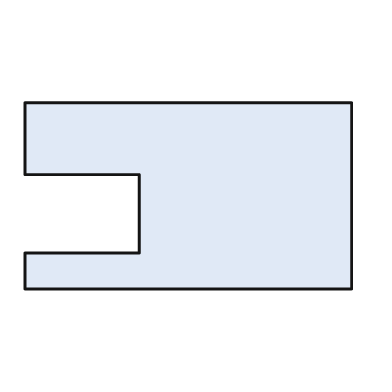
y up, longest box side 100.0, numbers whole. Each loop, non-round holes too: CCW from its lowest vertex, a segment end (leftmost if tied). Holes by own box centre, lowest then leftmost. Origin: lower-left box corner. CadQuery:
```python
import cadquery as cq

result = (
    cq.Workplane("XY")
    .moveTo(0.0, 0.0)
    .lineTo(100.0, 0.0)
    .lineTo(100.0, 57.0)
    .lineTo(0.0, 57.0)
    .lineTo(0.0, 35.0)
    .lineTo(35.0, 35.0)
    .lineTo(35.0, 11.0)
    .lineTo(0.0, 11.0)
    .close()
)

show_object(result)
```